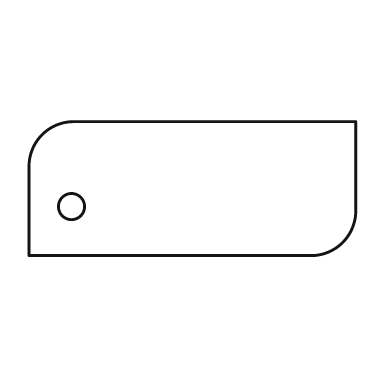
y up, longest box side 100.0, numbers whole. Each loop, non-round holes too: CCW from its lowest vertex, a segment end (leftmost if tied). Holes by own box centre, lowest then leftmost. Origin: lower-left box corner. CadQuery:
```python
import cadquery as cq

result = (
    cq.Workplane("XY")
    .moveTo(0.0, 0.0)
    .lineTo(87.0, 0.0)
    .threePointArc((96.0, 4.0), (100.0, 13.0))
    .lineTo(100.0, 41.0)
    .lineTo(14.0, 41.0)
    .threePointArc((4.0, 37.0), (0.0, 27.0))
    .close()
    .moveTo(13.0, 15.0)
    .circle(4.0)
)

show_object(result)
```